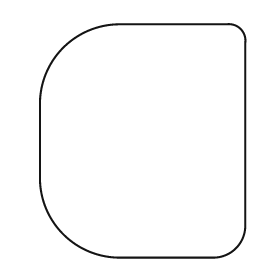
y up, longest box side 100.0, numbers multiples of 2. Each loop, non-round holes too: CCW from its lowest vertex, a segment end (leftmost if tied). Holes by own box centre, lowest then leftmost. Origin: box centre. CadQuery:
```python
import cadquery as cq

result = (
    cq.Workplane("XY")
    .moveTo(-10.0, -50.0)
    .lineTo(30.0, -50.0)
    .threePointArc((40.0, -46.0), (44.0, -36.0))
    .lineTo(44.0, 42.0)
    .threePointArc((42.0, 48.0), (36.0, 50.0))
    .lineTo(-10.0, 50.0)
    .threePointArc((-34.0, 40.0), (-44.0, 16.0))
    .lineTo(-44.0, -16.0)
    .threePointArc((-34.0, -40.0), (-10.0, -50.0))
    .close()
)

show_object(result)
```